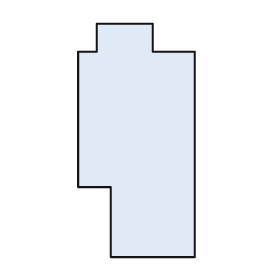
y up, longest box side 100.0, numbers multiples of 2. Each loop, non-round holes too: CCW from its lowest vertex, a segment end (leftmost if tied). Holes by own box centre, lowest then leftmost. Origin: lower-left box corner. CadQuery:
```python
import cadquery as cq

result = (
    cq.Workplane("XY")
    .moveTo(14.0, 0.0)
    .lineTo(50.0, 0.0)
    .lineTo(50.0, 88.0)
    .lineTo(32.0, 88.0)
    .lineTo(32.0, 100.0)
    .lineTo(8.0, 100.0)
    .lineTo(8.0, 88.0)
    .lineTo(0.0, 88.0)
    .lineTo(0.0, 30.0)
    .lineTo(14.0, 30.0)
    .close()
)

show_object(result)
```